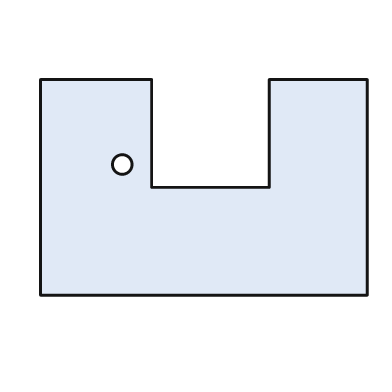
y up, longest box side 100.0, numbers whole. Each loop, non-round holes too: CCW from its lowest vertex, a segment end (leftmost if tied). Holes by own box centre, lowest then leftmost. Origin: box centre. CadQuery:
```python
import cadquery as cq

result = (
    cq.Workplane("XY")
    .moveTo(-50.0, -33.0)
    .lineTo(50.0, -33.0)
    .lineTo(50.0, 33.0)
    .lineTo(20.0, 33.0)
    .lineTo(20.0, 0.0)
    .lineTo(-16.0, 0.0)
    .lineTo(-16.0, 33.0)
    .lineTo(-50.0, 33.0)
    .close()
    .moveTo(-25.0, 7.0)
    .circle(3.0)
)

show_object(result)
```